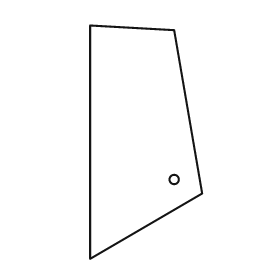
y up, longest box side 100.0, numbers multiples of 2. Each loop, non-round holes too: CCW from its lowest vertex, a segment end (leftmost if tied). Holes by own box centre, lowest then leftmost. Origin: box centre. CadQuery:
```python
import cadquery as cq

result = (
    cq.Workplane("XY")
    .moveTo(-24.0, -50.0)
    .lineTo(24.0, -22.0)
    .lineTo(12.0, 48.0)
    .lineTo(-24.0, 50.0)
    .close()
    .moveTo(12.0, -16.0)
    .circle(2.0)
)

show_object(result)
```